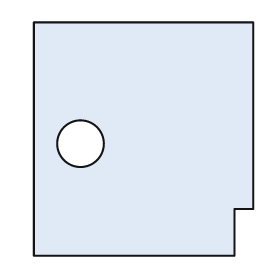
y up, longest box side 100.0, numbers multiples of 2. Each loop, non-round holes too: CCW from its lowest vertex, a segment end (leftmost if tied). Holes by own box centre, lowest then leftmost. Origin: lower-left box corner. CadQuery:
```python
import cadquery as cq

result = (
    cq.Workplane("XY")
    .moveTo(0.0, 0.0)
    .lineTo(86.0, 0.0)
    .lineTo(86.0, 20.0)
    .lineTo(94.0, 20.0)
    .lineTo(94.0, 100.0)
    .lineTo(0.0, 100.0)
    .close()
    .moveTo(20.0, 48.0)
    .circle(10.0)
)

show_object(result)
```